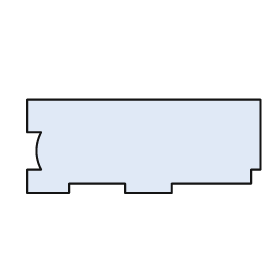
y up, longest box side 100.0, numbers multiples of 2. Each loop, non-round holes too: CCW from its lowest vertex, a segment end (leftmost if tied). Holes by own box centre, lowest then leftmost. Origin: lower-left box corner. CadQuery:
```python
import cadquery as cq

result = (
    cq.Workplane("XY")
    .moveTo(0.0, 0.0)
    .lineTo(18.0, 0.0)
    .lineTo(18.0, 4.0)
    .lineTo(42.0, 4.0)
    .lineTo(42.0, 0.0)
    .lineTo(62.0, 0.0)
    .lineTo(62.0, 4.0)
    .lineTo(96.0, 4.0)
    .lineTo(96.0, 10.0)
    .lineTo(100.0, 10.0)
    .lineTo(100.0, 40.0)
    .lineTo(0.0, 40.0)
    .lineTo(0.0, 26.0)
    .lineTo(6.0, 26.0)
    .threePointArc((4.0, 18.0), (6.0, 10.0))
    .lineTo(0.0, 10.0)
    .close()
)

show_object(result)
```